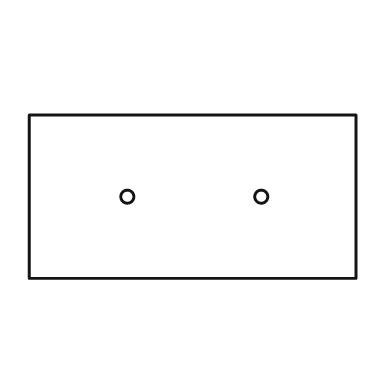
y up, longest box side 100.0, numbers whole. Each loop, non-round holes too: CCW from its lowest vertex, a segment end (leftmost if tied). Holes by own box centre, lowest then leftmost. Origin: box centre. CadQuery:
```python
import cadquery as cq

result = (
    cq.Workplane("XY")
    .moveTo(-50.0, -25.0)
    .lineTo(50.0, -25.0)
    .lineTo(50.0, 25.0)
    .lineTo(-50.0, 25.0)
    .close()
    .moveTo(-20.0, 0.0)
    .circle(2.0)
    .moveTo(21.0, 0.0)
    .circle(2.0)
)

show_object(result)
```